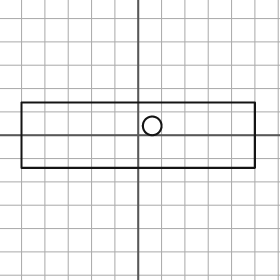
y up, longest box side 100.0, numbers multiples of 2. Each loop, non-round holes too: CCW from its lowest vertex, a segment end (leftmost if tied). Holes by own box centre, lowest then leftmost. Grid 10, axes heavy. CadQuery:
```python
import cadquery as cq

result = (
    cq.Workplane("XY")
    .moveTo(-50.0, -14.0)
    .lineTo(50.0, -14.0)
    .lineTo(50.0, 14.0)
    .lineTo(-50.0, 14.0)
    .close()
    .moveTo(6.0, 4.0)
    .circle(4.0)
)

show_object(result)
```